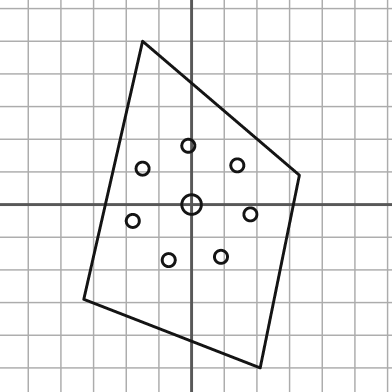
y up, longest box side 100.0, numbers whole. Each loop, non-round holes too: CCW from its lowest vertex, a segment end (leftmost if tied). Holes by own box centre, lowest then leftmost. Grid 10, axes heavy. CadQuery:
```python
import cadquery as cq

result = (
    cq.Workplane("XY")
    .moveTo(21.0, -50.0)
    .lineTo(33.0, 9.0)
    .lineTo(-15.0, 50.0)
    .lineTo(-33.0, -29.0)
    .close()
    .moveTo(-7.0, -17.0)
    .circle(2.0)
    .moveTo(9.0, -16.0)
    .circle(2.0)
    .moveTo(-18.0, -5.0)
    .circle(2.0)
    .moveTo(18.0, -3.0)
    .circle(2.0)
    .moveTo(0.0, 0.0)
    .circle(3.0)
    .moveTo(-15.0, 11.0)
    .circle(2.0)
    .moveTo(14.0, 12.0)
    .circle(2.0)
    .moveTo(-1.0, 18.0)
    .circle(2.0)
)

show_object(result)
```